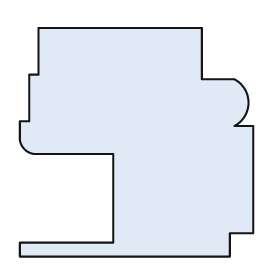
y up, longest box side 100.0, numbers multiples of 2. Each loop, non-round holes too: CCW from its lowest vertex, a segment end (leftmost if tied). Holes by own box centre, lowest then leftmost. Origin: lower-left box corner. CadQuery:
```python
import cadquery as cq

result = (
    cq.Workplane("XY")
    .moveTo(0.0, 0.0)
    .lineTo(90.0, 0.0)
    .lineTo(90.0, 10.0)
    .lineTo(100.0, 10.0)
    .lineTo(100.0, 56.0)
    .lineTo(92.0, 56.0)
    .threePointArc((98.0, 66.0), (92.0, 76.0))
    .lineTo(78.0, 76.0)
    .lineTo(78.0, 98.0)
    .lineTo(8.0, 98.0)
    .lineTo(8.0, 78.0)
    .lineTo(4.0, 78.0)
    .lineTo(4.0, 58.0)
    .lineTo(0.0, 58.0)
    .lineTo(0.0, 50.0)
    .threePointArc((2.0, 46.0), (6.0, 44.0))
    .lineTo(40.0, 44.0)
    .lineTo(40.0, 6.0)
    .lineTo(0.0, 6.0)
    .close()
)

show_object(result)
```